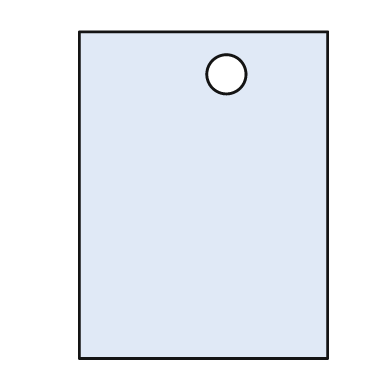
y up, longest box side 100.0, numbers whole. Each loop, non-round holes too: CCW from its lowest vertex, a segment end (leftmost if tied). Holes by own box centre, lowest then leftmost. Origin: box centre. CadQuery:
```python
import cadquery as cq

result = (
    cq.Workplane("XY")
    .moveTo(-38.0, -50.0)
    .lineTo(38.0, -50.0)
    .lineTo(38.0, 50.0)
    .lineTo(-38.0, 50.0)
    .close()
    .moveTo(7.0, 37.0)
    .circle(6.0)
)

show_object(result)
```